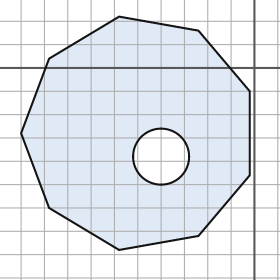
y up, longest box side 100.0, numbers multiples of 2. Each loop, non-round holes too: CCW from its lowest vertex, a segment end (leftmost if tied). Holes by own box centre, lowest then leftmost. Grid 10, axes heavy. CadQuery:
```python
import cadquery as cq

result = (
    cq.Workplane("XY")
    .moveTo(-58.0, -78.0)
    .lineTo(-24.0, -72.0)
    .lineTo(-2.0, -46.0)
    .lineTo(-2.0, -10.0)
    .lineTo(-24.0, 16.0)
    .lineTo(-58.0, 22.0)
    .lineTo(-88.0, 4.0)
    .lineTo(-100.0, -28.0)
    .lineTo(-88.0, -60.0)
    .close()
    .moveTo(-40.0, -38.0)
    .circle(12.0)
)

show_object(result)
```